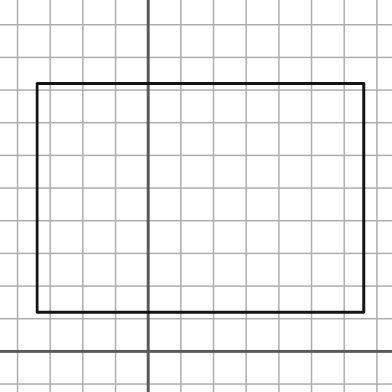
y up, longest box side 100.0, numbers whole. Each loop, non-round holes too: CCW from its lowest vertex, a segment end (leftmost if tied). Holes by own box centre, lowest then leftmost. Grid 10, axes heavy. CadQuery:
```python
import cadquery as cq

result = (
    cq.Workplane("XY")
    .moveTo(-34.0, 12.0)
    .lineTo(66.0, 12.0)
    .lineTo(66.0, 82.0)
    .lineTo(-34.0, 82.0)
    .close()
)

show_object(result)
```